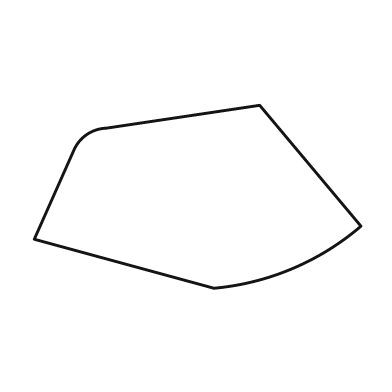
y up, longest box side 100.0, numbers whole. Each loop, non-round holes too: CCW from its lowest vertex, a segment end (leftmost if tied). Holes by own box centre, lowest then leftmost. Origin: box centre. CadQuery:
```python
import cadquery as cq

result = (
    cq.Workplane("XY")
    .moveTo(5.0, -28.0)
    .threePointArc((29.0, -22.0), (50.0, -9.0))
    .lineTo(19.0, 28.0)
    .lineTo(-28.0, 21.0)
    .threePointArc((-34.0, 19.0), (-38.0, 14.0))
    .lineTo(-50.0, -13.0)
    .close()
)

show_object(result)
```